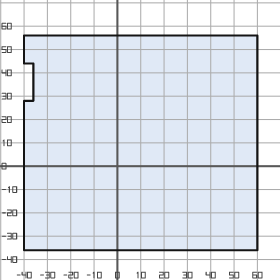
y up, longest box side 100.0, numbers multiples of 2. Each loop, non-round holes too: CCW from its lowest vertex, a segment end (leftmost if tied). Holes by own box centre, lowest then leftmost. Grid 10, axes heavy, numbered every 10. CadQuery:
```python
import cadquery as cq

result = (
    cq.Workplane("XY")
    .moveTo(-40.0, -36.0)
    .lineTo(60.0, -36.0)
    .lineTo(60.0, 56.0)
    .lineTo(-40.0, 56.0)
    .lineTo(-40.0, 44.0)
    .lineTo(-36.0, 44.0)
    .lineTo(-36.0, 28.0)
    .lineTo(-40.0, 28.0)
    .close()
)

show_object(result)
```